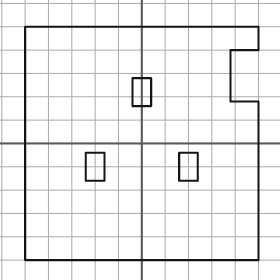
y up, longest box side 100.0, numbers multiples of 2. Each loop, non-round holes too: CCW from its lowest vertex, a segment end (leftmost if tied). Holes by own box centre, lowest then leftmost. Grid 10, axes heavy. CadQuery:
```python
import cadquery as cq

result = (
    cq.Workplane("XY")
    .moveTo(-50.0, -50.0)
    .lineTo(50.0, -50.0)
    .lineTo(50.0, 18.0)
    .lineTo(38.0, 18.0)
    .lineTo(38.0, 40.0)
    .lineTo(50.0, 40.0)
    .lineTo(50.0, 50.0)
    .lineTo(-50.0, 50.0)
    .close()
    .moveTo(-24.0, -16.0)
    .lineTo(-16.0, -16.0)
    .lineTo(-16.0, -4.0)
    .lineTo(-24.0, -4.0)
    .close()
    .moveTo(16.0, -16.0)
    .lineTo(24.0, -16.0)
    .lineTo(24.0, -4.0)
    .lineTo(16.0, -4.0)
    .close()
    .moveTo(-4.0, 16.0)
    .lineTo(4.0, 16.0)
    .lineTo(4.0, 28.0)
    .lineTo(-4.0, 28.0)
    .close()
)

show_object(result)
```